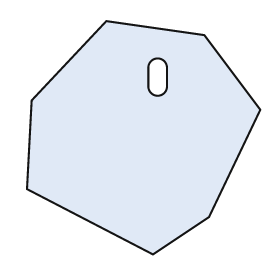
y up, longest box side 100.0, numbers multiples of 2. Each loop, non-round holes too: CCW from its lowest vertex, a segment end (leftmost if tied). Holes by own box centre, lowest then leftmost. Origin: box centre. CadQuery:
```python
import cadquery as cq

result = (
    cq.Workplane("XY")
    .moveTo(4.0, -50.0)
    .lineTo(28.0, -34.0)
    .lineTo(50.0, 12.0)
    .lineTo(26.0, 44.0)
    .lineTo(-16.0, 50.0)
    .lineTo(-48.0, 16.0)
    .lineTo(-50.0, -22.0)
    .close()
    .moveTo(2.0, 22.0)
    .threePointArc((6.0, 18.0), (10.0, 22.0))
    .lineTo(10.0, 30.0)
    .threePointArc((6.0, 34.0), (2.0, 30.0))
    .close()
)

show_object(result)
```